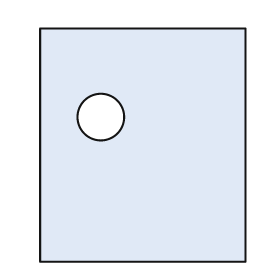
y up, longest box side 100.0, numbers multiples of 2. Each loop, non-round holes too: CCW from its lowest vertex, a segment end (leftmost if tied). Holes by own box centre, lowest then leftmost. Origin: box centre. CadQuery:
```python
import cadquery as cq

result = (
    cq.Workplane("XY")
    .moveTo(-44.0, -50.0)
    .lineTo(44.0, -50.0)
    .lineTo(44.0, 50.0)
    .lineTo(-44.0, 50.0)
    .close()
    .moveTo(-18.0, 12.0)
    .circle(10.0)
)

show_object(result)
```